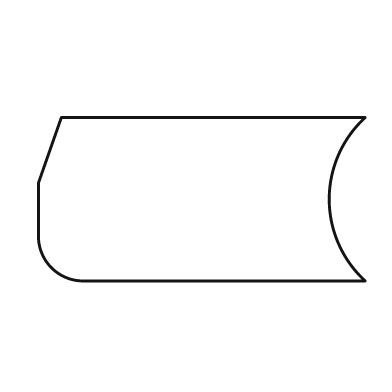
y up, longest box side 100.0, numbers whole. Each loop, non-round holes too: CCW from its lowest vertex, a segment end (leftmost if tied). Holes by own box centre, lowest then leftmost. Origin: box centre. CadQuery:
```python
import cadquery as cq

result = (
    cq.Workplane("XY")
    .moveTo(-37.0, -25.0)
    .lineTo(50.0, -25.0)
    .threePointArc((39.0, 0.0), (50.0, 25.0))
    .lineTo(-43.0, 25.0)
    .lineTo(-50.0, 5.0)
    .lineTo(-50.0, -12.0)
    .threePointArc((-46.0, -21.0), (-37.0, -25.0))
    .close()
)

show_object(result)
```